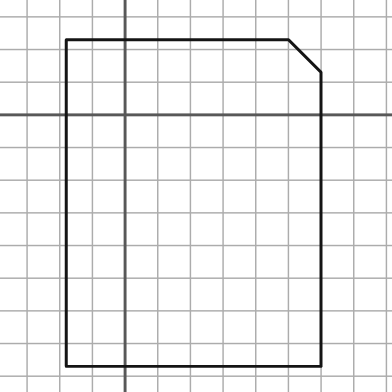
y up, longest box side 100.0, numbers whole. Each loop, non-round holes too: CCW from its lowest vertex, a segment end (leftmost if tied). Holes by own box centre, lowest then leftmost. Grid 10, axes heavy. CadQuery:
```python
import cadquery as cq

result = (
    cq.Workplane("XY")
    .moveTo(-18.0, -77.0)
    .lineTo(60.0, -77.0)
    .lineTo(60.0, 13.0)
    .lineTo(50.0, 23.0)
    .lineTo(-18.0, 23.0)
    .close()
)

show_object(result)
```